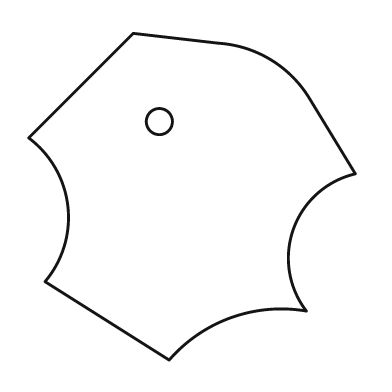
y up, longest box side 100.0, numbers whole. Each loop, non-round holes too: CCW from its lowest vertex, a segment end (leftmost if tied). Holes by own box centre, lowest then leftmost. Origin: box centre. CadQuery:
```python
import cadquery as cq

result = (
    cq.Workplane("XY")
    .moveTo(-7.0, -50.0)
    .threePointArc((12.0, -37.0), (35.0, -35.0))
    .threePointArc((31.0, -10.0), (50.0, 7.0))
    .lineTo(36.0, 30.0)
    .threePointArc((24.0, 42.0), (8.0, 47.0))
    .lineTo(-18.0, 50.0)
    .lineTo(-50.0, 18.0)
    .threePointArc((-38.0, -3.0), (-45.0, -26.0))
    .close()
    .moveTo(-10.0, 23.0)
    .circle(4.0)
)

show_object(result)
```